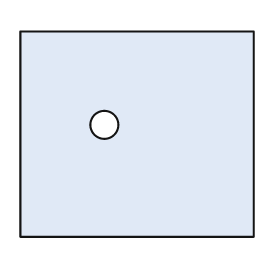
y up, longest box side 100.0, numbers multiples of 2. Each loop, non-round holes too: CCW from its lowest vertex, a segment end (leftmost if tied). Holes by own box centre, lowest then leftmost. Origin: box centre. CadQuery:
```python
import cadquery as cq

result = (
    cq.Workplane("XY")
    .moveTo(-50.0, -44.0)
    .lineTo(50.0, -44.0)
    .lineTo(50.0, 44.0)
    .lineTo(-50.0, 44.0)
    .close()
    .moveTo(-14.0, 4.0)
    .circle(6.0)
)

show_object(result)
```